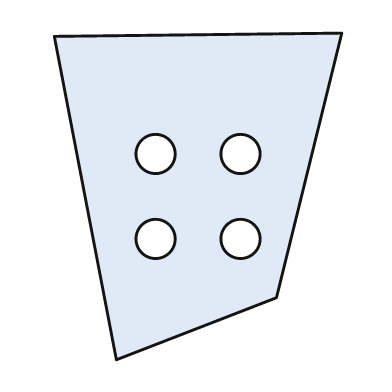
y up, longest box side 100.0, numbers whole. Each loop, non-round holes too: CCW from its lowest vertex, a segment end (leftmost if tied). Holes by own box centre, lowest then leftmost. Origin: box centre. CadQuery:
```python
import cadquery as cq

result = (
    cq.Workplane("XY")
    .moveTo(-25.0, -50.0)
    .lineTo(24.0, -31.0)
    .lineTo(44.0, 50.0)
    .lineTo(-44.0, 49.0)
    .close()
    .moveTo(-13.0, -13.0)
    .circle(6.0)
    .moveTo(13.0, -13.0)
    .circle(6.0)
    .moveTo(-13.0, 13.0)
    .circle(6.0)
    .moveTo(13.0, 13.0)
    .circle(6.0)
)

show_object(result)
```